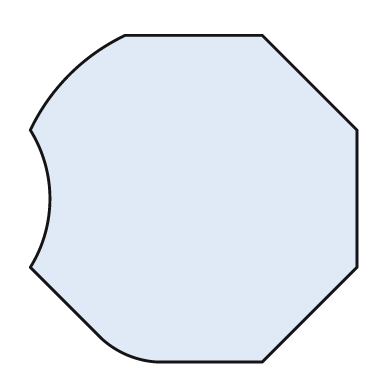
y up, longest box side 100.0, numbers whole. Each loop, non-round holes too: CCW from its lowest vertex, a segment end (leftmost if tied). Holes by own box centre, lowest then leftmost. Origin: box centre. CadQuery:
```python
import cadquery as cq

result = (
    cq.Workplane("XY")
    .moveTo(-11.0, -50.0)
    .lineTo(21.0, -50.0)
    .lineTo(50.0, -21.0)
    .lineTo(50.0, 21.0)
    .lineTo(21.0, 50.0)
    .lineTo(-21.0, 50.0)
    .threePointArc((-38.0, 38.0), (-50.0, 21.0))
    .threePointArc((-44.0, 0.0), (-50.0, -21.0))
    .lineTo(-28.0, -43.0)
    .threePointArc((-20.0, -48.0), (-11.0, -50.0))
    .close()
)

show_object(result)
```